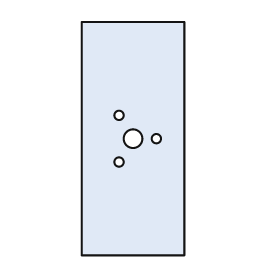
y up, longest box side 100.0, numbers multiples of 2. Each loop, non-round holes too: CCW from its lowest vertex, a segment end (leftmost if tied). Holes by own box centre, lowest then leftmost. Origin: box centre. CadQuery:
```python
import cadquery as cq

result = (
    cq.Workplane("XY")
    .moveTo(-22.0, -50.0)
    .lineTo(22.0, -50.0)
    .lineTo(22.0, 50.0)
    .lineTo(-22.0, 50.0)
    .close()
    .moveTo(-6.0, -10.0)
    .circle(2.0)
    .moveTo(0.0, 0.0)
    .circle(4.0)
    .moveTo(10.0, 0.0)
    .circle(2.0)
    .moveTo(-6.0, 10.0)
    .circle(2.0)
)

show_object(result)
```